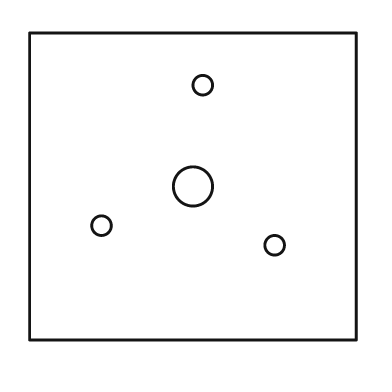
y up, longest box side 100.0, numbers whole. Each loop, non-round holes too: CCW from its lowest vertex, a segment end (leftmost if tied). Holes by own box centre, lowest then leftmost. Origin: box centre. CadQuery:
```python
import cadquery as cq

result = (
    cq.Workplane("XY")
    .moveTo(-50.0, -47.0)
    .lineTo(50.0, -47.0)
    .lineTo(50.0, 47.0)
    .lineTo(-50.0, 47.0)
    .close()
    .moveTo(25.0, -18.0)
    .circle(3.0)
    .moveTo(-28.0, -12.0)
    .circle(3.0)
    .moveTo(0.0, 0.0)
    .circle(6.0)
    .moveTo(3.0, 31.0)
    .circle(3.0)
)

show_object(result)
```